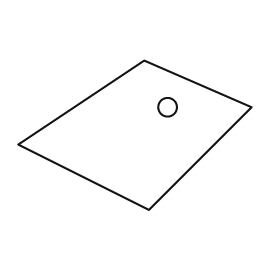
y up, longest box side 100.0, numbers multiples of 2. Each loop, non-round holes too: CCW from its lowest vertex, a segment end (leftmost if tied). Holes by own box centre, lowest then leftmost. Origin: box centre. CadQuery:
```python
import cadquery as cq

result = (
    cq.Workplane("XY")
    .moveTo(6.0, -32.0)
    .lineTo(50.0, 12.0)
    .lineTo(4.0, 32.0)
    .lineTo(-50.0, -4.0)
    .close()
    .moveTo(14.0, 12.0)
    .circle(4.0)
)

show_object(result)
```